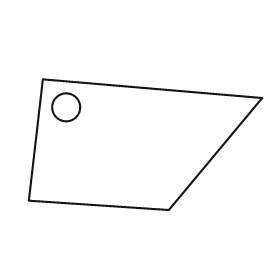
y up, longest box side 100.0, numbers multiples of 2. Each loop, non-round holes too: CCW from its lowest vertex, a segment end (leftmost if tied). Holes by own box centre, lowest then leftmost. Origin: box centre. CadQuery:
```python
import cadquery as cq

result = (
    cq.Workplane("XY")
    .moveTo(10.0, -28.0)
    .lineTo(50.0, 20.0)
    .lineTo(-44.0, 28.0)
    .lineTo(-50.0, -24.0)
    .close()
    .moveTo(-34.0, 16.0)
    .circle(6.0)
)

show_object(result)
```